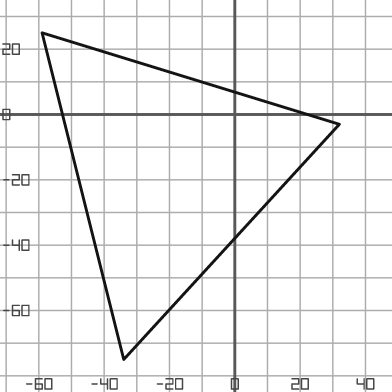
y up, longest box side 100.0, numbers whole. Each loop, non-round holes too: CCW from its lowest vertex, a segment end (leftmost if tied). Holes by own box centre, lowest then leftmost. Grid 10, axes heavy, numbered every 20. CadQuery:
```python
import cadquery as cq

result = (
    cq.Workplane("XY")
    .moveTo(-34.0, -75.0)
    .lineTo(32.0, -3.0)
    .lineTo(-59.0, 25.0)
    .close()
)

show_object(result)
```